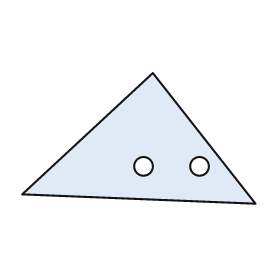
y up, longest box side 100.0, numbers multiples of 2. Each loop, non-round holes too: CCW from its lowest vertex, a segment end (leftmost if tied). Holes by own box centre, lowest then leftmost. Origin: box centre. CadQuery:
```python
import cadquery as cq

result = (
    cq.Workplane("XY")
    .moveTo(50.0, -28.0)
    .lineTo(6.0, 28.0)
    .lineTo(-50.0, -24.0)
    .close()
    .moveTo(2.0, -12.0)
    .circle(4.0)
    .moveTo(26.0, -12.0)
    .circle(4.0)
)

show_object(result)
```